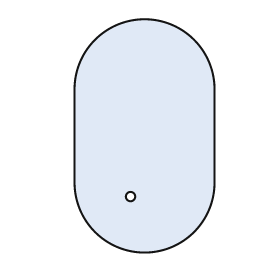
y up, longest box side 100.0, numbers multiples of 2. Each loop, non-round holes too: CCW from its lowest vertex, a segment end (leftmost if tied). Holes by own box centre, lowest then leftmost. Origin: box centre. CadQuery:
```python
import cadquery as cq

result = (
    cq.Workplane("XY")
    .moveTo(-30.0, -20.0)
    .threePointArc((0.0, -50.0), (30.0, -20.0))
    .lineTo(30.0, 20.0)
    .threePointArc((0.0, 50.0), (-30.0, 20.0))
    .close()
    .moveTo(-6.0, -26.0)
    .circle(2.0)
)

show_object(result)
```